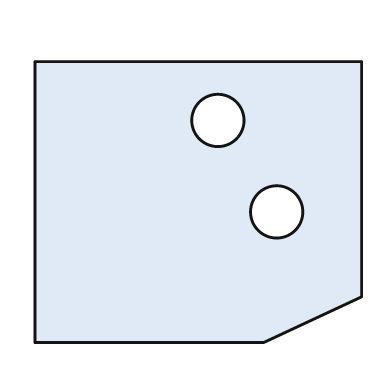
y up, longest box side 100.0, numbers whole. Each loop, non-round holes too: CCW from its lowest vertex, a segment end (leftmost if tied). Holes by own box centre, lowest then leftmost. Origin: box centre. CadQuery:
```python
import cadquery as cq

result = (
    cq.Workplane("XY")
    .moveTo(-50.0, -43.0)
    .lineTo(20.0, -43.0)
    .lineTo(50.0, -29.0)
    .lineTo(50.0, 43.0)
    .lineTo(-50.0, 43.0)
    .close()
    .moveTo(24.0, -3.0)
    .circle(8.0)
    .moveTo(6.0, 25.0)
    .circle(8.0)
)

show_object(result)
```